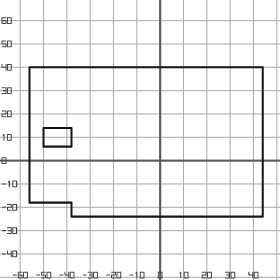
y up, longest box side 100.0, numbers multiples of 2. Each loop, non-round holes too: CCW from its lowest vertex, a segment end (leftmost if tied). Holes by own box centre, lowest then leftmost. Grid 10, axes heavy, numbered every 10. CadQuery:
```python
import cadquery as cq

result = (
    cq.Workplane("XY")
    .moveTo(-38.0, -24.0)
    .lineTo(44.0, -24.0)
    .lineTo(44.0, 40.0)
    .lineTo(-56.0, 40.0)
    .lineTo(-56.0, -18.0)
    .lineTo(-38.0, -18.0)
    .close()
    .moveTo(-50.0, 6.0)
    .lineTo(-38.0, 6.0)
    .lineTo(-38.0, 14.0)
    .lineTo(-50.0, 14.0)
    .close()
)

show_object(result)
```